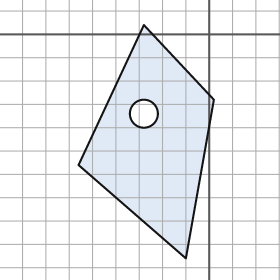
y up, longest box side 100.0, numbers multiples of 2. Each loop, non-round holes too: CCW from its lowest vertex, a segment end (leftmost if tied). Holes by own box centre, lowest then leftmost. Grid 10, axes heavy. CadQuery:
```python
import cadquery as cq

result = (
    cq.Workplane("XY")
    .moveTo(-10.0, -96.0)
    .lineTo(2.0, -28.0)
    .lineTo(-28.0, 4.0)
    .lineTo(-56.0, -56.0)
    .close()
    .moveTo(-28.0, -34.0)
    .circle(6.0)
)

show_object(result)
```